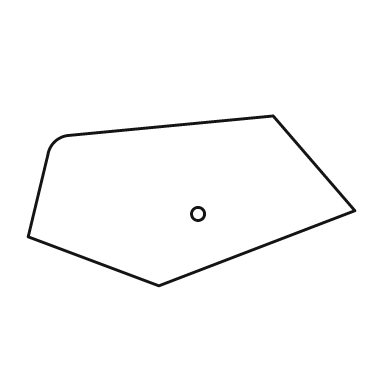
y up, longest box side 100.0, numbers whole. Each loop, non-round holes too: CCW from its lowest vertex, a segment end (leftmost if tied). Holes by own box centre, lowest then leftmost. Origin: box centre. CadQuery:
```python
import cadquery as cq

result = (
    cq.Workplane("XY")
    .moveTo(-10.0, -26.0)
    .lineTo(50.0, -3.0)
    .lineTo(25.0, 26.0)
    .lineTo(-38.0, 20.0)
    .threePointArc((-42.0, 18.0), (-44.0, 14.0))
    .lineTo(-50.0, -11.0)
    .close()
    .moveTo(2.0, -4.0)
    .circle(2.0)
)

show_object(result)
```